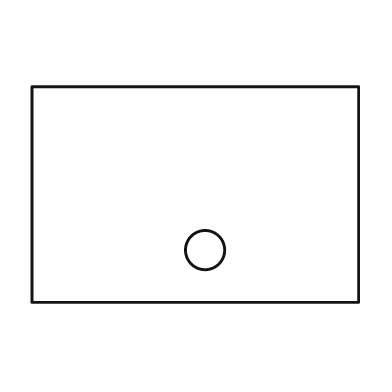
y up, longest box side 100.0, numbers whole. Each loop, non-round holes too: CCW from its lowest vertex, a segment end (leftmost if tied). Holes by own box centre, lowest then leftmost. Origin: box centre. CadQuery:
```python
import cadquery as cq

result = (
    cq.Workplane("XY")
    .moveTo(-50.0, -33.0)
    .lineTo(50.0, -33.0)
    .lineTo(50.0, 33.0)
    .lineTo(-50.0, 33.0)
    .close()
    .moveTo(3.0, -17.0)
    .circle(6.0)
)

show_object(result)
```